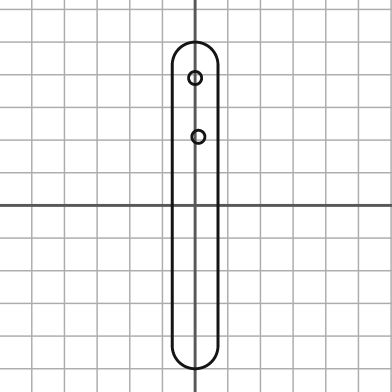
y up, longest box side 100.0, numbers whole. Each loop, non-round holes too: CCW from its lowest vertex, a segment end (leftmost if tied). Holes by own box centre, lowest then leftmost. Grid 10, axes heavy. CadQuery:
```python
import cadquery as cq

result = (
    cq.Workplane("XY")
    .moveTo(-7.0, -43.0)
    .threePointArc((0.0, -50.0), (7.0, -43.0))
    .lineTo(7.0, 43.0)
    .threePointArc((0.0, 50.0), (-7.0, 43.0))
    .close()
    .moveTo(1.0, 21.0)
    .circle(2.0)
    .moveTo(0.0, 39.0)
    .circle(2.0)
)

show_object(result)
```